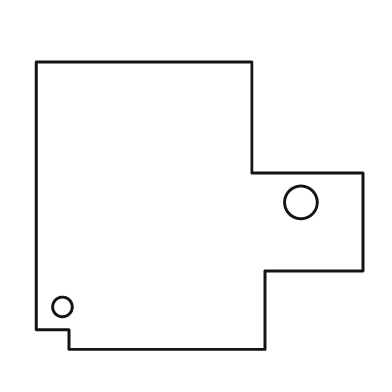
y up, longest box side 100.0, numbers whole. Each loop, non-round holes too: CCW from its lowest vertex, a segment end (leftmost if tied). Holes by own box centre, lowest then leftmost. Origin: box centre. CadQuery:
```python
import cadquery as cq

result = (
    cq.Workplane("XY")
    .moveTo(-40.0, -44.0)
    .lineTo(20.0, -44.0)
    .lineTo(20.0, -20.0)
    .lineTo(50.0, -20.0)
    .lineTo(50.0, 10.0)
    .lineTo(16.0, 10.0)
    .lineTo(16.0, 44.0)
    .lineTo(-50.0, 44.0)
    .lineTo(-50.0, -38.0)
    .lineTo(-40.0, -38.0)
    .close()
    .moveTo(-42.0, -31.0)
    .circle(3.0)
    .moveTo(31.0, 1.0)
    .circle(5.0)
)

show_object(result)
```